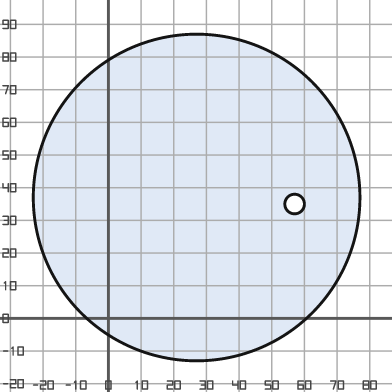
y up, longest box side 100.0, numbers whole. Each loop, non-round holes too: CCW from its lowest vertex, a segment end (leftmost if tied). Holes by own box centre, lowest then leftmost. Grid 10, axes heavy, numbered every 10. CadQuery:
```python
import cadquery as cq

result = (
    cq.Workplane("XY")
    .moveTo(27.0, 37.0)
    .circle(50.0)
    .moveTo(57.0, 35.0)
    .circle(3.0)
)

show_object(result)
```